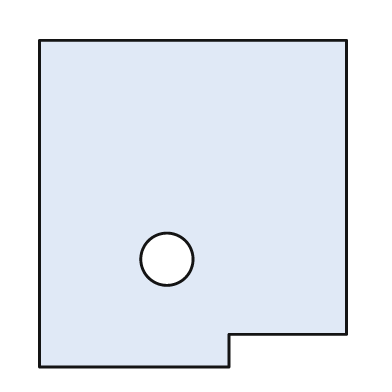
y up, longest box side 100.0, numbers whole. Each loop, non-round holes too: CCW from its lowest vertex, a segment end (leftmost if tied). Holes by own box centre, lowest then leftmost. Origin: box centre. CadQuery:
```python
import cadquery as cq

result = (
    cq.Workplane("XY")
    .moveTo(-47.0, -50.0)
    .lineTo(11.0, -50.0)
    .lineTo(11.0, -40.0)
    .lineTo(47.0, -40.0)
    .lineTo(47.0, 50.0)
    .lineTo(-47.0, 50.0)
    .close()
    .moveTo(-8.0, -17.0)
    .circle(8.0)
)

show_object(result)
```